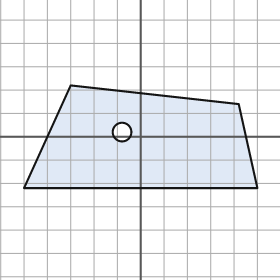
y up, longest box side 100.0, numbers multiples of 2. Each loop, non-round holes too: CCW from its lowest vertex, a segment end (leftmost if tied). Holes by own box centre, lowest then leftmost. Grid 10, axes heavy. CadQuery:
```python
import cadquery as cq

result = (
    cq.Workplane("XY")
    .moveTo(-50.0, -22.0)
    .lineTo(50.0, -22.0)
    .lineTo(42.0, 14.0)
    .lineTo(-30.0, 22.0)
    .close()
    .moveTo(-8.0, 2.0)
    .circle(4.0)
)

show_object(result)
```